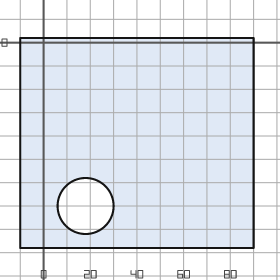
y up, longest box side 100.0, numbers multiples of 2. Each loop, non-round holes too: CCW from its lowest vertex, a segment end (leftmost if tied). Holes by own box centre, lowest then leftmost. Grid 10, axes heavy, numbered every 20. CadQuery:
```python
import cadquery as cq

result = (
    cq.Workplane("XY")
    .moveTo(-10.0, -88.0)
    .lineTo(90.0, -88.0)
    .lineTo(90.0, 2.0)
    .lineTo(-10.0, 2.0)
    .close()
    .moveTo(18.0, -70.0)
    .circle(12.0)
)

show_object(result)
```